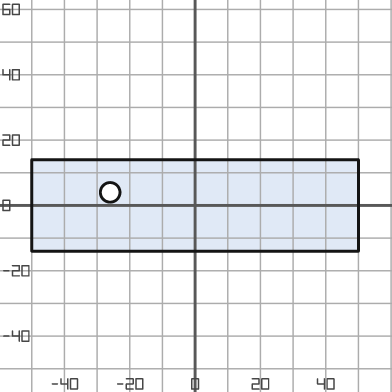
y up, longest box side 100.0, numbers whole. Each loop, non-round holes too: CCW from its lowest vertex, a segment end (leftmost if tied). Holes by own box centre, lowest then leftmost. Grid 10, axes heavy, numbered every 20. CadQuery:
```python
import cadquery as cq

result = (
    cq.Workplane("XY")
    .moveTo(-50.0, -14.0)
    .lineTo(50.0, -14.0)
    .lineTo(50.0, 14.0)
    .lineTo(-50.0, 14.0)
    .close()
    .moveTo(-26.0, 4.0)
    .circle(3.0)
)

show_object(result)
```